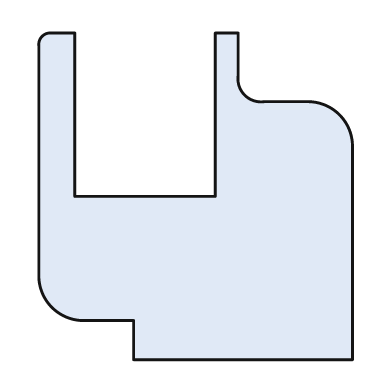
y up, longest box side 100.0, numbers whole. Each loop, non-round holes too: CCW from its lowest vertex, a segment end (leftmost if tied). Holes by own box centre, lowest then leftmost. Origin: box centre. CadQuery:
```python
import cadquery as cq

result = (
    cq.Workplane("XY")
    .moveTo(-19.0, -50.0)
    .lineTo(48.0, -50.0)
    .lineTo(48.0, 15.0)
    .threePointArc((44.0, 25.0), (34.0, 29.0))
    .lineTo(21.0, 29.0)
    .threePointArc((15.0, 31.0), (13.0, 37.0))
    .lineTo(13.0, 50.0)
    .lineTo(6.0, 50.0)
    .lineTo(6.0, 0.0)
    .lineTo(-37.0, 0.0)
    .lineTo(-37.0, 50.0)
    .lineTo(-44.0, 50.0)
    .threePointArc((-47.0, 49.0), (-48.0, 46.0))
    .lineTo(-48.0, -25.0)
    .threePointArc((-44.0, -34.0), (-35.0, -38.0))
    .lineTo(-19.0, -38.0)
    .close()
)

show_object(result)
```